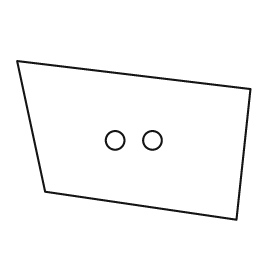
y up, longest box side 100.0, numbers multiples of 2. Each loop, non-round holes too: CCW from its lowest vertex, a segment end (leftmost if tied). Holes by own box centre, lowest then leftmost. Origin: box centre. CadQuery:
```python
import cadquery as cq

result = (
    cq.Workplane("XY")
    .moveTo(44.0, -34.0)
    .lineTo(50.0, 22.0)
    .lineTo(-50.0, 34.0)
    .lineTo(-38.0, -22.0)
    .close()
    .moveTo(-8.0, 0.0)
    .circle(4.0)
    .moveTo(8.0, 0.0)
    .circle(4.0)
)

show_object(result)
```